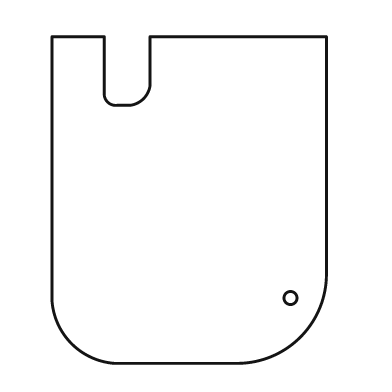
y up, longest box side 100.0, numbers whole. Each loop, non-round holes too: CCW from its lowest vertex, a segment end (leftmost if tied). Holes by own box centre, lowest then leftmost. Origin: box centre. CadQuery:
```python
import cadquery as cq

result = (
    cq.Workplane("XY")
    .moveTo(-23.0, -50.0)
    .lineTo(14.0, -50.0)
    .threePointArc((34.0, -42.0), (42.0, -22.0))
    .lineTo(42.0, 50.0)
    .lineTo(-12.0, 50.0)
    .lineTo(-12.0, 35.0)
    .threePointArc((-14.0, 31.0), (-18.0, 29.0))
    .lineTo(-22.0, 29.0)
    .threePointArc((-25.0, 30.0), (-26.0, 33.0))
    .lineTo(-26.0, 50.0)
    .lineTo(-42.0, 50.0)
    .lineTo(-42.0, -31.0)
    .threePointArc((-36.0, -44.0), (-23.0, -50.0))
    .close()
    .moveTo(31.0, -30.0)
    .circle(2.0)
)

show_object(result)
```